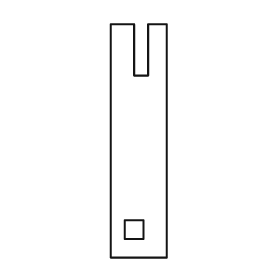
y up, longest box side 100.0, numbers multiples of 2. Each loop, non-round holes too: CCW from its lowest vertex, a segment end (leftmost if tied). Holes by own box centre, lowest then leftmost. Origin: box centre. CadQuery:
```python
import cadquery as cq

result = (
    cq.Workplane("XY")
    .moveTo(-12.0, -50.0)
    .lineTo(12.0, -50.0)
    .lineTo(12.0, 50.0)
    .lineTo(4.0, 50.0)
    .lineTo(4.0, 28.0)
    .lineTo(-2.0, 28.0)
    .lineTo(-2.0, 50.0)
    .lineTo(-12.0, 50.0)
    .close()
    .moveTo(-6.0, -42.0)
    .lineTo(2.0, -42.0)
    .lineTo(2.0, -34.0)
    .lineTo(-6.0, -34.0)
    .close()
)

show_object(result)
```